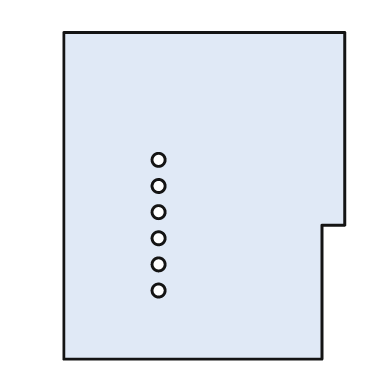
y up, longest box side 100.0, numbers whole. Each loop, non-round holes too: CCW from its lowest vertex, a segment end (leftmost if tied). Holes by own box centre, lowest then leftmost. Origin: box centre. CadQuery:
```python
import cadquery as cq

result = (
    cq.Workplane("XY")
    .moveTo(-43.0, -50.0)
    .lineTo(36.0, -50.0)
    .lineTo(36.0, -9.0)
    .lineTo(43.0, -9.0)
    .lineTo(43.0, 50.0)
    .lineTo(-43.0, 50.0)
    .close()
    .moveTo(-14.0, -29.0)
    .circle(2.0)
    .moveTo(-14.0, -21.0)
    .circle(2.0)
    .moveTo(-14.0, -13.0)
    .circle(2.0)
    .moveTo(-14.0, -5.0)
    .circle(2.0)
    .moveTo(-14.0, 3.0)
    .circle(2.0)
    .moveTo(-14.0, 11.0)
    .circle(2.0)
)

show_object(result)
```